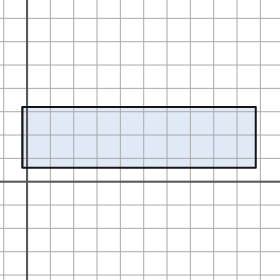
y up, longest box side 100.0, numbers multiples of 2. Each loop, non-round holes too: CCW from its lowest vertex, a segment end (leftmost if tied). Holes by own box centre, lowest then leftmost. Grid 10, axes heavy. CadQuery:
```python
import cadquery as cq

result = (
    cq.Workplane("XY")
    .moveTo(-2.0, 6.0)
    .lineTo(98.0, 6.0)
    .lineTo(98.0, 32.0)
    .lineTo(-2.0, 32.0)
    .close()
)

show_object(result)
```